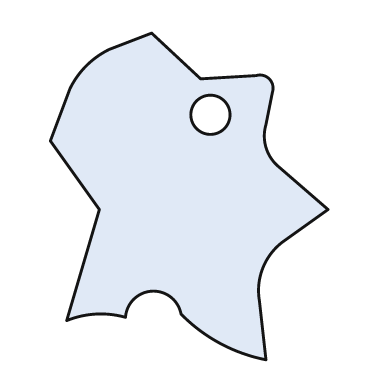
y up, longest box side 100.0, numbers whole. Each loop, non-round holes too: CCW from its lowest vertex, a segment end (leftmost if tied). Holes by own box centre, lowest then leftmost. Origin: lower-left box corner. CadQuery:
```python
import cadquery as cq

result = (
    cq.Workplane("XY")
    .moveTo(66.0, 0.0)
    .lineTo(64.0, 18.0)
    .threePointArc((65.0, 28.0), (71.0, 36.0))
    .lineTo(85.0, 46.0)
    .lineTo(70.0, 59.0)
    .threePointArc((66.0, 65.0), (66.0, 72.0))
    .lineTo(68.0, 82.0)
    .threePointArc((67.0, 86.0), (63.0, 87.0))
    .lineTo(46.0, 86.0)
    .lineTo(31.0, 100.0)
    .lineTo(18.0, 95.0)
    .threePointArc((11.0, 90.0), (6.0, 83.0))
    .lineTo(0.0, 67.0)
    .lineTo(15.0, 46.0)
    .lineTo(5.0, 12.0)
    .threePointArc((14.0, 14.0), (23.0, 13.0))
    .threePointArc((31.0, 21.0), (40.0, 14.0))
    .threePointArc((52.0, 5.0), (66.0, 0.0))
    .close()
    .moveTo(49.0, 75.0)
    .circle(6.0)
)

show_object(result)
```